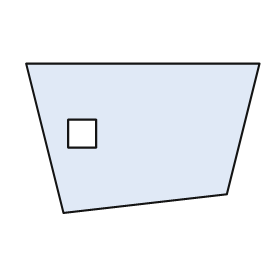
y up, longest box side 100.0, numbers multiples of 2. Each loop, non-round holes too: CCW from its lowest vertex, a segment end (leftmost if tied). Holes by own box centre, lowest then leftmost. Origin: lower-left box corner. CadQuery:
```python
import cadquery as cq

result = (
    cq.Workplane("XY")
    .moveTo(16.0, 0.0)
    .lineTo(86.0, 8.0)
    .lineTo(100.0, 64.0)
    .lineTo(0.0, 64.0)
    .close()
    .moveTo(18.0, 28.0)
    .lineTo(30.0, 28.0)
    .lineTo(30.0, 40.0)
    .lineTo(18.0, 40.0)
    .close()
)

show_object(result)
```